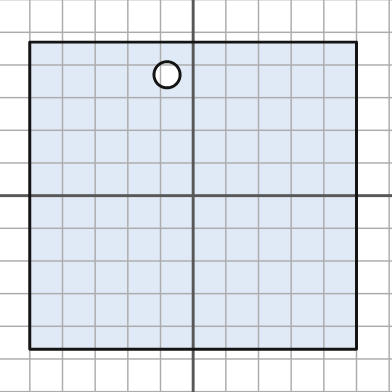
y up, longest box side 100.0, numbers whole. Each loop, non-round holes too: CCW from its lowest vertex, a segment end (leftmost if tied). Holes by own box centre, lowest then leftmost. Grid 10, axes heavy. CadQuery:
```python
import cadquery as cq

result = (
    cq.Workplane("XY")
    .moveTo(-50.0, -47.0)
    .lineTo(50.0, -47.0)
    .lineTo(50.0, 47.0)
    .lineTo(-50.0, 47.0)
    .close()
    .moveTo(-8.0, 37.0)
    .circle(4.0)
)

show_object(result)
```